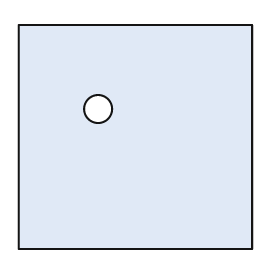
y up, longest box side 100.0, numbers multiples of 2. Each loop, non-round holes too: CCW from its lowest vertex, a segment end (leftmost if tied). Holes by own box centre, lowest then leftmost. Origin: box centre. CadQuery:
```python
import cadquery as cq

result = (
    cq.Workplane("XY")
    .moveTo(-50.0, -48.0)
    .lineTo(50.0, -48.0)
    .lineTo(50.0, 48.0)
    .lineTo(-50.0, 48.0)
    .close()
    .moveTo(-16.0, 12.0)
    .circle(6.0)
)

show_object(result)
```